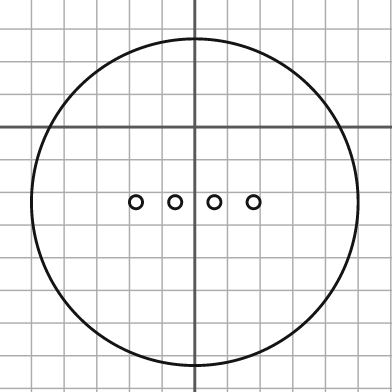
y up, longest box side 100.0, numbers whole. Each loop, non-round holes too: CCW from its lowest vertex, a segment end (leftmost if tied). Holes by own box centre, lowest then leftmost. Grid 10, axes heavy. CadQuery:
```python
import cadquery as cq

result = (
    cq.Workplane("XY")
    .moveTo(0.0, -23.0)
    .circle(50.0)
    .moveTo(-18.0, -23.0)
    .circle(2.0)
    .moveTo(-6.0, -23.0)
    .circle(2.0)
    .moveTo(6.0, -23.0)
    .circle(2.0)
    .moveTo(18.0, -23.0)
    .circle(2.0)
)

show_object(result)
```